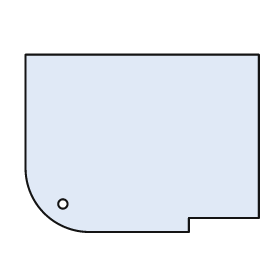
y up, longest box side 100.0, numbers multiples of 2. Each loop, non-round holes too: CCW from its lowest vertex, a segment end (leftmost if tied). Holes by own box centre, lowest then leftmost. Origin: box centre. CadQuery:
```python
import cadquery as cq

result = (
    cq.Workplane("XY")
    .moveTo(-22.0, -38.0)
    .lineTo(20.0, -38.0)
    .lineTo(20.0, -32.0)
    .lineTo(50.0, -32.0)
    .lineTo(50.0, 38.0)
    .lineTo(-50.0, 38.0)
    .lineTo(-50.0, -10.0)
    .threePointArc((-42.0, -30.0), (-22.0, -38.0))
    .close()
    .moveTo(-34.0, -26.0)
    .circle(2.0)
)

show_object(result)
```